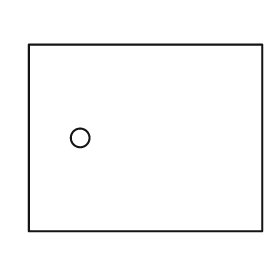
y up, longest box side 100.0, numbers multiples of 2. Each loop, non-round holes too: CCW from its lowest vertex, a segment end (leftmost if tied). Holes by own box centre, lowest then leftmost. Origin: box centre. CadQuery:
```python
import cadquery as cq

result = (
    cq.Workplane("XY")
    .moveTo(-50.0, -40.0)
    .lineTo(50.0, -40.0)
    .lineTo(50.0, 40.0)
    .lineTo(-50.0, 40.0)
    .close()
    .moveTo(-28.0, 0.0)
    .circle(4.0)
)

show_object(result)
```